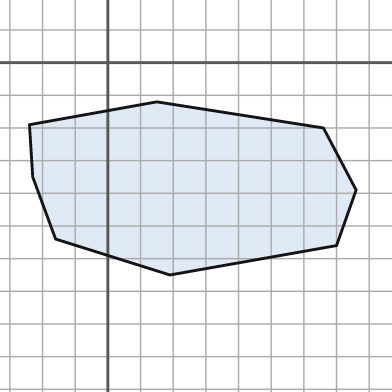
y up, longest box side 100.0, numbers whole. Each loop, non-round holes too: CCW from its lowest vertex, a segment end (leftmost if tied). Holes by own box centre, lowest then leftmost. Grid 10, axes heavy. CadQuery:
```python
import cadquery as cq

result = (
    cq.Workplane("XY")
    .moveTo(19.0, -65.0)
    .lineTo(70.0, -56.0)
    .lineTo(76.0, -39.0)
    .lineTo(66.0, -20.0)
    .lineTo(15.0, -12.0)
    .lineTo(-24.0, -19.0)
    .lineTo(-23.0, -35.0)
    .lineTo(-16.0, -54.0)
    .close()
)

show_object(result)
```